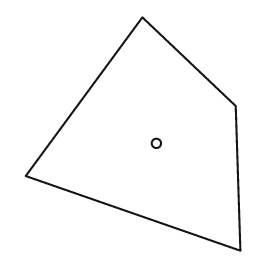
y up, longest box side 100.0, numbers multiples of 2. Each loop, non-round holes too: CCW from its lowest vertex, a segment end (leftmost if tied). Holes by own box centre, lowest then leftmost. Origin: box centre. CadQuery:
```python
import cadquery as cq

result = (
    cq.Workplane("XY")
    .moveTo(46.0, -50.0)
    .lineTo(44.0, 12.0)
    .lineTo(4.0, 50.0)
    .lineTo(-46.0, -18.0)
    .close()
    .moveTo(10.0, -4.0)
    .circle(2.0)
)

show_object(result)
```